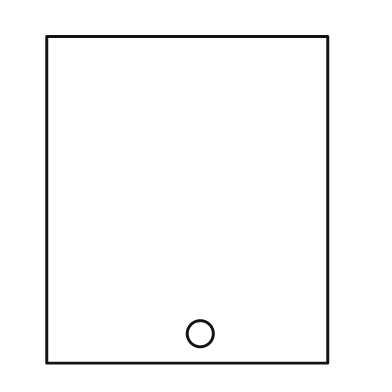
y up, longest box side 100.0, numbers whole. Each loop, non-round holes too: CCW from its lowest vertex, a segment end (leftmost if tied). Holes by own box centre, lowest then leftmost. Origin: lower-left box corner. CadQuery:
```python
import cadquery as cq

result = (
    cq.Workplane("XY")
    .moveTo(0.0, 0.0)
    .lineTo(86.0, 0.0)
    .lineTo(86.0, 100.0)
    .lineTo(0.0, 100.0)
    .close()
    .moveTo(47.0, 9.0)
    .circle(4.0)
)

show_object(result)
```